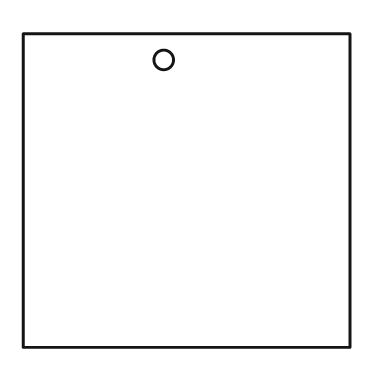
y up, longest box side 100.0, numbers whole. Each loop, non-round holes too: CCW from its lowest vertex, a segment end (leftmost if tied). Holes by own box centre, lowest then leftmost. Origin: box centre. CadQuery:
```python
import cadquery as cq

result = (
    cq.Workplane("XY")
    .moveTo(-50.0, -48.0)
    .lineTo(50.0, -48.0)
    .lineTo(50.0, 48.0)
    .lineTo(-50.0, 48.0)
    .close()
    .moveTo(-7.0, 40.0)
    .circle(3.0)
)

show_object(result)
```